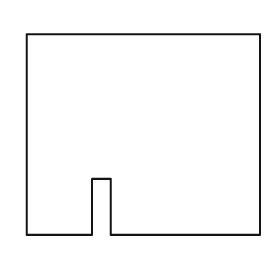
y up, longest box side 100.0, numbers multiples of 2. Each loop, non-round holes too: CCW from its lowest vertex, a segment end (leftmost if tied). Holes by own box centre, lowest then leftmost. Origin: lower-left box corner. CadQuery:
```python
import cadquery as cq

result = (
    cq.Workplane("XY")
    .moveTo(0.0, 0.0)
    .lineTo(28.0, 0.0)
    .lineTo(28.0, 24.0)
    .lineTo(36.0, 24.0)
    .lineTo(36.0, 0.0)
    .lineTo(100.0, 0.0)
    .lineTo(100.0, 86.0)
    .lineTo(0.0, 86.0)
    .close()
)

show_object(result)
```